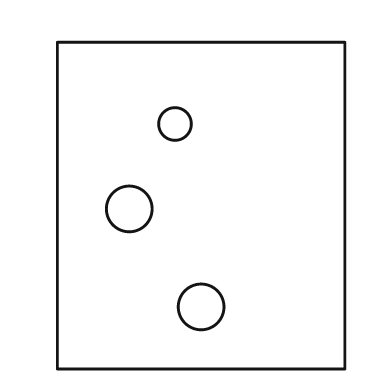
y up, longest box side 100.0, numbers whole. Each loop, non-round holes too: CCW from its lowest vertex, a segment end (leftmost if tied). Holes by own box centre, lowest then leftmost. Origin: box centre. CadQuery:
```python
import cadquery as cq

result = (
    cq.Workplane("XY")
    .moveTo(-44.0, -50.0)
    .lineTo(44.0, -50.0)
    .lineTo(44.0, 50.0)
    .lineTo(-44.0, 50.0)
    .close()
    .moveTo(0.0, -31.0)
    .circle(7.0)
    .moveTo(-22.0, -1.0)
    .circle(7.0)
    .moveTo(-8.0, 25.0)
    .circle(5.0)
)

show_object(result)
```